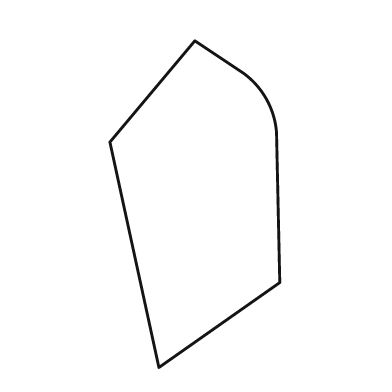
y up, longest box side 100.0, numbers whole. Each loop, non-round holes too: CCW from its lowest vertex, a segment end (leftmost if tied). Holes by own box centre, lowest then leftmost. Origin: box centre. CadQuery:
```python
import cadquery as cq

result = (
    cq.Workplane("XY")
    .moveTo(-11.0, -50.0)
    .lineTo(26.0, -24.0)
    .lineTo(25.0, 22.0)
    .threePointArc((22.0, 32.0), (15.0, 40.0))
    .lineTo(0.0, 50.0)
    .lineTo(-26.0, 19.0)
    .close()
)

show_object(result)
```